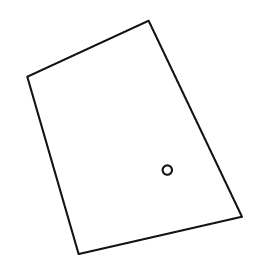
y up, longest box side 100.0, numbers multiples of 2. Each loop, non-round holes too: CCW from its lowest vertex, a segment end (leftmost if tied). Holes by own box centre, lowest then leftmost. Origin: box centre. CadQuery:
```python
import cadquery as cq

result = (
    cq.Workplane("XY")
    .moveTo(-24.0, -50.0)
    .lineTo(46.0, -34.0)
    .lineTo(6.0, 50.0)
    .lineTo(-46.0, 26.0)
    .close()
    .moveTo(14.0, -14.0)
    .circle(2.0)
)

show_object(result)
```